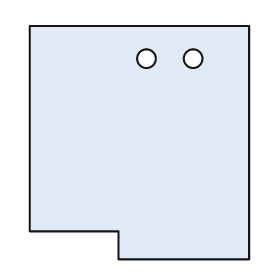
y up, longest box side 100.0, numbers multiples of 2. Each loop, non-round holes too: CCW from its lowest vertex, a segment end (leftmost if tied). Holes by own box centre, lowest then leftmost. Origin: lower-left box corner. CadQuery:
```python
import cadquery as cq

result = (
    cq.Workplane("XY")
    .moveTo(38.0, 0.0)
    .lineTo(94.0, 0.0)
    .lineTo(94.0, 100.0)
    .lineTo(0.0, 100.0)
    .lineTo(0.0, 12.0)
    .lineTo(38.0, 12.0)
    .close()
    .moveTo(50.0, 86.0)
    .circle(4.0)
    .moveTo(70.0, 86.0)
    .circle(4.0)
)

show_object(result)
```